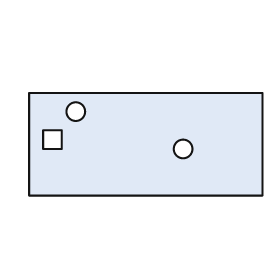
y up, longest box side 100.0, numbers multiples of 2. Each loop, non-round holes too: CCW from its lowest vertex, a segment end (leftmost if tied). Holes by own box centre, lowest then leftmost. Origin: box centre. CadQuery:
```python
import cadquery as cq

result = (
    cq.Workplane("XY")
    .moveTo(-50.0, -22.0)
    .lineTo(50.0, -22.0)
    .lineTo(50.0, 22.0)
    .lineTo(-50.0, 22.0)
    .close()
    .moveTo(16.0, -2.0)
    .circle(4.0)
    .moveTo(-44.0, -2.0)
    .lineTo(-36.0, -2.0)
    .lineTo(-36.0, 6.0)
    .lineTo(-44.0, 6.0)
    .close()
    .moveTo(-30.0, 14.0)
    .circle(4.0)
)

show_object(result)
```